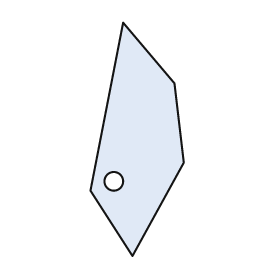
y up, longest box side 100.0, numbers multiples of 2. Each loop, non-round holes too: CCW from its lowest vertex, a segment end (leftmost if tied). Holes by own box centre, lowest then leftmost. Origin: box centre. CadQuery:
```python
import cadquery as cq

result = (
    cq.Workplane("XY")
    .moveTo(-2.0, -50.0)
    .lineTo(20.0, -10.0)
    .lineTo(16.0, 24.0)
    .lineTo(-6.0, 50.0)
    .lineTo(-20.0, -22.0)
    .close()
    .moveTo(-10.0, -18.0)
    .circle(4.0)
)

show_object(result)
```